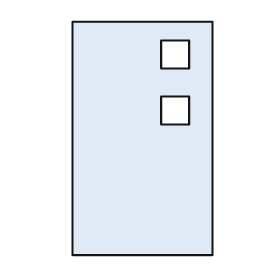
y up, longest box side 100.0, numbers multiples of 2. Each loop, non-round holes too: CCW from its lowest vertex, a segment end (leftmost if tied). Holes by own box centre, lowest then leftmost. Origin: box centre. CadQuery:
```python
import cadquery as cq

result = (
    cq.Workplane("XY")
    .moveTo(-30.0, -50.0)
    .lineTo(30.0, -50.0)
    .lineTo(30.0, 50.0)
    .lineTo(-30.0, 50.0)
    .close()
    .moveTo(8.0, 6.0)
    .lineTo(20.0, 6.0)
    .lineTo(20.0, 18.0)
    .lineTo(8.0, 18.0)
    .close()
    .moveTo(8.0, 30.0)
    .lineTo(20.0, 30.0)
    .lineTo(20.0, 42.0)
    .lineTo(8.0, 42.0)
    .close()
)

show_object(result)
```